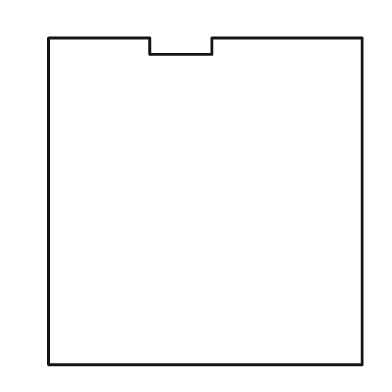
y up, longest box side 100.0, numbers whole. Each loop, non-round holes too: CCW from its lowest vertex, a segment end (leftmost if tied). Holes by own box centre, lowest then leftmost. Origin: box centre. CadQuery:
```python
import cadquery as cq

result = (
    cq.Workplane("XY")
    .moveTo(-48.0, -50.0)
    .lineTo(48.0, -50.0)
    .lineTo(48.0, 50.0)
    .lineTo(2.0, 50.0)
    .lineTo(2.0, 45.0)
    .lineTo(-17.0, 45.0)
    .lineTo(-17.0, 50.0)
    .lineTo(-48.0, 50.0)
    .close()
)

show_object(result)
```